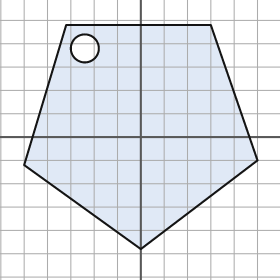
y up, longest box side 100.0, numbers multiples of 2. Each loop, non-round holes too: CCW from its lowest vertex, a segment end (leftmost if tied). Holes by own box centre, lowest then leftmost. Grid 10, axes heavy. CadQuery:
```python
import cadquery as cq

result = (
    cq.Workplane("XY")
    .moveTo(0.0, -48.0)
    .lineTo(50.0, -10.0)
    .lineTo(30.0, 48.0)
    .lineTo(-32.0, 48.0)
    .lineTo(-50.0, -12.0)
    .close()
    .moveTo(-24.0, 38.0)
    .circle(6.0)
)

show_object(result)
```